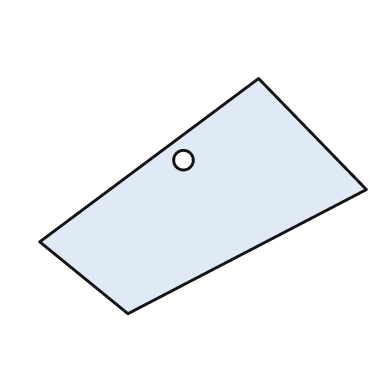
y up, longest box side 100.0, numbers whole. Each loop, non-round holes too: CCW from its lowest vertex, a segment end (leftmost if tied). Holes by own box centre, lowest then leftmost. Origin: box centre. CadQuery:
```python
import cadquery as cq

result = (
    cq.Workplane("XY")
    .moveTo(-23.0, -36.0)
    .lineTo(50.0, 2.0)
    .lineTo(17.0, 36.0)
    .lineTo(-50.0, -14.0)
    .close()
    .moveTo(-6.0, 11.0)
    .circle(3.0)
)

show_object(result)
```